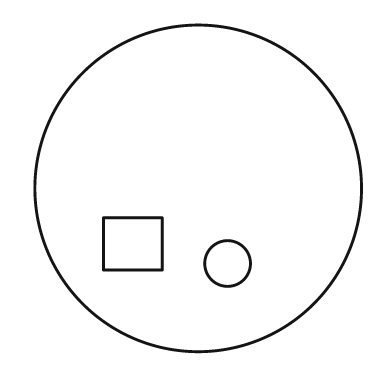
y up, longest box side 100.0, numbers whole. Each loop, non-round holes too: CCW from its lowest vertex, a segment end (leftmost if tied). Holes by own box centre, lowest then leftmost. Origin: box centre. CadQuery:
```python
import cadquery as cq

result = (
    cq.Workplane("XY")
    .moveTo(0.0, 0.0)
    .circle(50.0)
    .moveTo(9.0, -23.0)
    .circle(7.0)
    .moveTo(-29.0, -25.0)
    .lineTo(-11.0, -25.0)
    .lineTo(-11.0, -9.0)
    .lineTo(-29.0, -9.0)
    .close()
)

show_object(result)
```